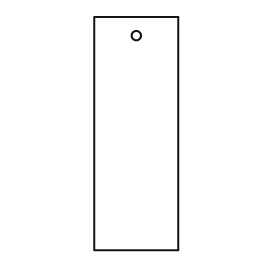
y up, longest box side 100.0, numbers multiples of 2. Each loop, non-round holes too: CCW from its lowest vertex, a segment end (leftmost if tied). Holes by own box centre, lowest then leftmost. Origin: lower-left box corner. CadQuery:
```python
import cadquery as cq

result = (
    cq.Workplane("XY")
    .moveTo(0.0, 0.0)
    .lineTo(36.0, 0.0)
    .lineTo(36.0, 100.0)
    .lineTo(0.0, 100.0)
    .close()
    .moveTo(18.0, 92.0)
    .circle(2.0)
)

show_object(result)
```